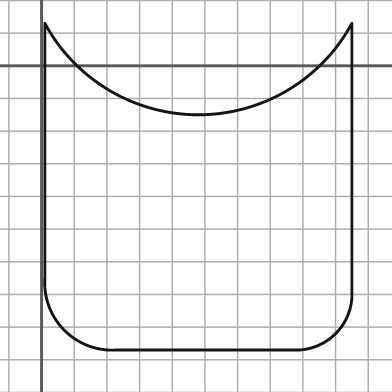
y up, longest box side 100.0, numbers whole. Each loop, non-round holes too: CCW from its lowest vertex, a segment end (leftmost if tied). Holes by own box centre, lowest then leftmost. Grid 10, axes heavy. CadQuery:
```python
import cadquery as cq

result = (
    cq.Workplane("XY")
    .moveTo(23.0, -87.0)
    .lineTo(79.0, -87.0)
    .threePointArc((90.0, -82.0), (95.0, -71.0))
    .lineTo(95.0, 13.0)
    .threePointArc((48.0, -15.0), (1.0, 13.0))
    .lineTo(1.0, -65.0)
    .threePointArc((7.0, -81.0), (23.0, -87.0))
    .close()
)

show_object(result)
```